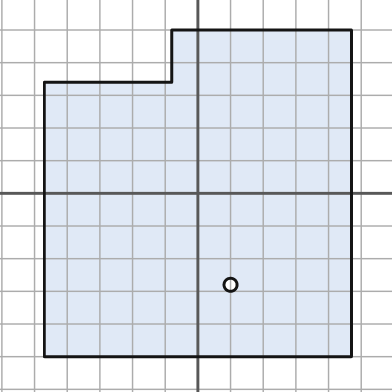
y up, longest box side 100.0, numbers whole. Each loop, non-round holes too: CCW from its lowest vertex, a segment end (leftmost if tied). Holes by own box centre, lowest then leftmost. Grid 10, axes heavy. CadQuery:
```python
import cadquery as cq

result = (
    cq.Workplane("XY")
    .moveTo(-47.0, -50.0)
    .lineTo(47.0, -50.0)
    .lineTo(47.0, 50.0)
    .lineTo(-8.0, 50.0)
    .lineTo(-8.0, 34.0)
    .lineTo(-47.0, 34.0)
    .close()
    .moveTo(10.0, -28.0)
    .circle(2.0)
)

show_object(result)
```